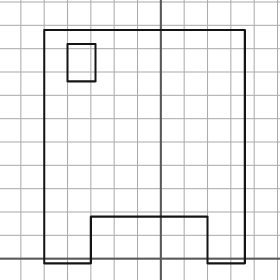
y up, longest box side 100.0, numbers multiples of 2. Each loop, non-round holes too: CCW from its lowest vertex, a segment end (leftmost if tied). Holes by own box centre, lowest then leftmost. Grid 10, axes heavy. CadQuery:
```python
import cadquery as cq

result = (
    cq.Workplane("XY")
    .moveTo(-50.0, -2.0)
    .lineTo(-30.0, -2.0)
    .lineTo(-30.0, 18.0)
    .lineTo(20.0, 18.0)
    .lineTo(20.0, -2.0)
    .lineTo(36.0, -2.0)
    .lineTo(36.0, 98.0)
    .lineTo(-50.0, 98.0)
    .close()
    .moveTo(-40.0, 76.0)
    .lineTo(-28.0, 76.0)
    .lineTo(-28.0, 92.0)
    .lineTo(-40.0, 92.0)
    .close()
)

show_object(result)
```